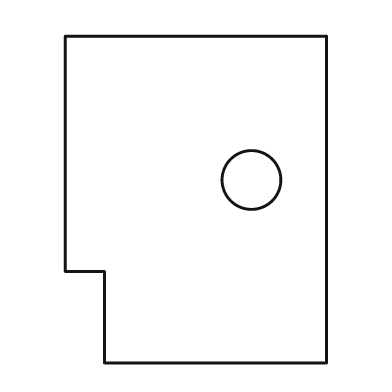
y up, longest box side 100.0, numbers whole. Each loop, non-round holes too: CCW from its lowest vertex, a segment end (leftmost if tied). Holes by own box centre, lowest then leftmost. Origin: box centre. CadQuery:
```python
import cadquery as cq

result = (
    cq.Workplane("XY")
    .moveTo(-28.0, -50.0)
    .lineTo(40.0, -50.0)
    .lineTo(40.0, 50.0)
    .lineTo(-40.0, 50.0)
    .lineTo(-40.0, -22.0)
    .lineTo(-28.0, -22.0)
    .close()
    .moveTo(17.0, 6.0)
    .circle(9.0)
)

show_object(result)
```